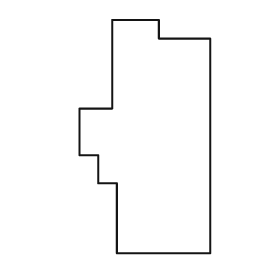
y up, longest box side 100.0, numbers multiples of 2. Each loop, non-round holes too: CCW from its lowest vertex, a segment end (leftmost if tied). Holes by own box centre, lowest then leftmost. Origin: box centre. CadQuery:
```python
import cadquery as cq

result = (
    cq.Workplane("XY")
    .moveTo(-12.0, -50.0)
    .lineTo(28.0, -50.0)
    .lineTo(28.0, 42.0)
    .lineTo(6.0, 42.0)
    .lineTo(6.0, 50.0)
    .lineTo(-14.0, 50.0)
    .lineTo(-14.0, 12.0)
    .lineTo(-28.0, 12.0)
    .lineTo(-28.0, -8.0)
    .lineTo(-20.0, -8.0)
    .lineTo(-20.0, -20.0)
    .lineTo(-12.0, -20.0)
    .close()
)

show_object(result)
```